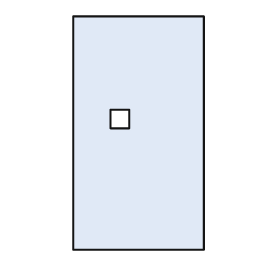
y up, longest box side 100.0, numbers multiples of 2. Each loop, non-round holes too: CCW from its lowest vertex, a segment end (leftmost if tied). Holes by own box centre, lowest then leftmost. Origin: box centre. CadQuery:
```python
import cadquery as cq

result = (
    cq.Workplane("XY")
    .moveTo(-28.0, -50.0)
    .lineTo(28.0, -50.0)
    .lineTo(28.0, 50.0)
    .lineTo(-28.0, 50.0)
    .close()
    .moveTo(-12.0, 2.0)
    .lineTo(-4.0, 2.0)
    .lineTo(-4.0, 10.0)
    .lineTo(-12.0, 10.0)
    .close()
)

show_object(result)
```